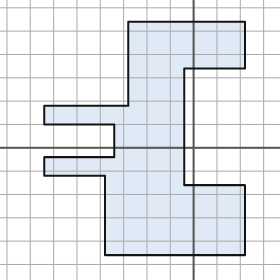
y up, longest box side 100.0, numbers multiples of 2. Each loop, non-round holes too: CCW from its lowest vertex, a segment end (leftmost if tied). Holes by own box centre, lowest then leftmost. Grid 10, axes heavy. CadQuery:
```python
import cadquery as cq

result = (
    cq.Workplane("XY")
    .moveTo(-38.0, -46.0)
    .lineTo(22.0, -46.0)
    .lineTo(22.0, -16.0)
    .lineTo(-4.0, -16.0)
    .lineTo(-4.0, 34.0)
    .lineTo(22.0, 34.0)
    .lineTo(22.0, 54.0)
    .lineTo(-28.0, 54.0)
    .lineTo(-28.0, 18.0)
    .lineTo(-64.0, 18.0)
    .lineTo(-64.0, 10.0)
    .lineTo(-34.0, 10.0)
    .lineTo(-34.0, -4.0)
    .lineTo(-64.0, -4.0)
    .lineTo(-64.0, -12.0)
    .lineTo(-38.0, -12.0)
    .close()
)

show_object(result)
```